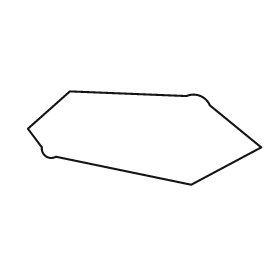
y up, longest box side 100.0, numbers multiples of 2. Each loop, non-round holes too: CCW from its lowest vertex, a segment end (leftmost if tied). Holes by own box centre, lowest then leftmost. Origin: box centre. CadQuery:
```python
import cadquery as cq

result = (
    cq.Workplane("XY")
    .moveTo(20.0, -20.0)
    .lineTo(50.0, -4.0)
    .lineTo(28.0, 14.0)
    .threePointArc((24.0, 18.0), (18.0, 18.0))
    .lineTo(-32.0, 20.0)
    .lineTo(-50.0, 4.0)
    .lineTo(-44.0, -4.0)
    .threePointArc((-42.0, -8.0), (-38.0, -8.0))
    .close()
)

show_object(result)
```